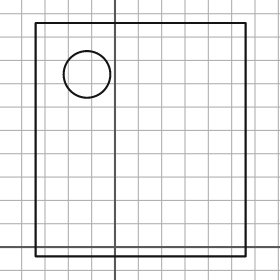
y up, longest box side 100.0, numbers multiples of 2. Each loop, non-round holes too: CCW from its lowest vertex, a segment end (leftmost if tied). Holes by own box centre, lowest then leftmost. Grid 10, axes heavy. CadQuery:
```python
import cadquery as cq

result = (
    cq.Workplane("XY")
    .moveTo(-34.0, -4.0)
    .lineTo(56.0, -4.0)
    .lineTo(56.0, 96.0)
    .lineTo(-34.0, 96.0)
    .close()
    .moveTo(-12.0, 74.0)
    .circle(10.0)
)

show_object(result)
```